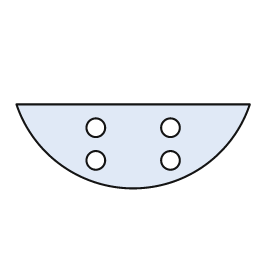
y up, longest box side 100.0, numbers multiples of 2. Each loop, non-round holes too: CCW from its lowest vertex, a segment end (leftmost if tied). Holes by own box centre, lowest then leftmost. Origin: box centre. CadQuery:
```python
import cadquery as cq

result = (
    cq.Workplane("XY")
    .moveTo(-50.0, 18.0)
    .threePointArc((0.0, -18.0), (50.0, 18.0))
    .close()
    .moveTo(-16.0, -6.0)
    .circle(4.0)
    .moveTo(16.0, -6.0)
    .circle(4.0)
    .moveTo(-16.0, 8.0)
    .circle(4.0)
    .moveTo(16.0, 8.0)
    .circle(4.0)
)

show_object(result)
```